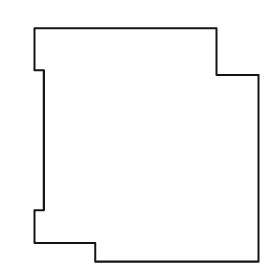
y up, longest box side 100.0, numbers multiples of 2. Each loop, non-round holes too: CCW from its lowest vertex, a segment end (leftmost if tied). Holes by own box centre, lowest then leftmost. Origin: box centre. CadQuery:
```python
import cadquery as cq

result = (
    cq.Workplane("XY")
    .moveTo(-22.0, -50.0)
    .lineTo(48.0, -50.0)
    .lineTo(48.0, 30.0)
    .lineTo(30.0, 30.0)
    .lineTo(30.0, 50.0)
    .lineTo(-48.0, 50.0)
    .lineTo(-48.0, 32.0)
    .lineTo(-44.0, 32.0)
    .lineTo(-44.0, -28.0)
    .lineTo(-48.0, -28.0)
    .lineTo(-48.0, -42.0)
    .lineTo(-22.0, -42.0)
    .close()
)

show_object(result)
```